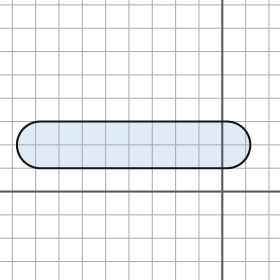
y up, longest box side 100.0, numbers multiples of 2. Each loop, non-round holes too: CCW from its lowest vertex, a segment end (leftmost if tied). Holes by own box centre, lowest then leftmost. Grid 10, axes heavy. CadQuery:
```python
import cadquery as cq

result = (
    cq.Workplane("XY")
    .moveTo(-78.0, 10.0)
    .lineTo(2.0, 10.0)
    .threePointArc((12.0, 20.0), (2.0, 30.0))
    .lineTo(-78.0, 30.0)
    .threePointArc((-88.0, 20.0), (-78.0, 10.0))
    .close()
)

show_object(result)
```